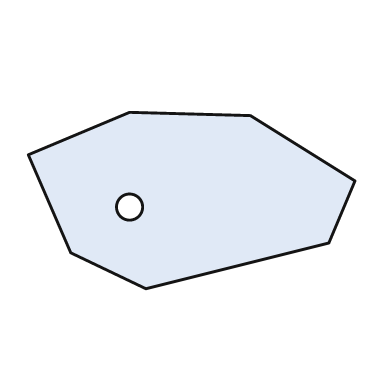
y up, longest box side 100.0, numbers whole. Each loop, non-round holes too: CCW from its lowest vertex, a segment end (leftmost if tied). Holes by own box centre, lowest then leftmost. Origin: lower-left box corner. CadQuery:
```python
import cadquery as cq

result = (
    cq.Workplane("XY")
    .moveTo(36.0, 0.0)
    .lineTo(92.0, 14.0)
    .lineTo(100.0, 33.0)
    .lineTo(68.0, 53.0)
    .lineTo(31.0, 54.0)
    .lineTo(0.0, 41.0)
    .lineTo(13.0, 11.0)
    .close()
    .moveTo(31.0, 25.0)
    .circle(4.0)
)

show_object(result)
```